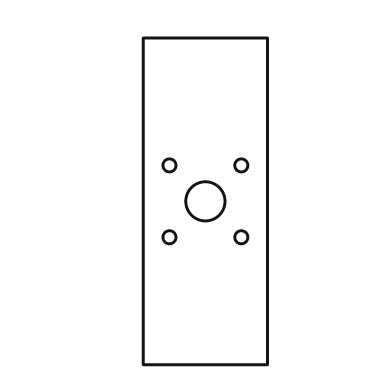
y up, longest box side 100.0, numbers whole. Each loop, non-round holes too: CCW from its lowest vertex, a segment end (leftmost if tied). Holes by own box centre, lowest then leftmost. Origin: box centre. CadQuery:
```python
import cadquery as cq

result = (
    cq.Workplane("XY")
    .moveTo(-19.0, -50.0)
    .lineTo(19.0, -50.0)
    .lineTo(19.0, 50.0)
    .lineTo(-19.0, 50.0)
    .close()
    .moveTo(-11.0, -11.0)
    .circle(2.0)
    .moveTo(11.0, -11.0)
    .circle(2.0)
    .moveTo(0.0, 0.0)
    .circle(6.0)
    .moveTo(-11.0, 11.0)
    .circle(2.0)
    .moveTo(11.0, 11.0)
    .circle(2.0)
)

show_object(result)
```